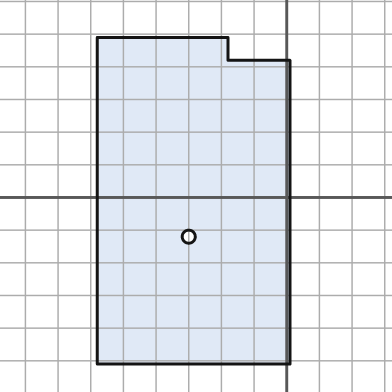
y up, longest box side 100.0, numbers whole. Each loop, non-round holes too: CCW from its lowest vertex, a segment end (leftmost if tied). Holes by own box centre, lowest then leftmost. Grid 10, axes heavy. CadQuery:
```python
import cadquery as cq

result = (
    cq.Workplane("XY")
    .moveTo(-58.0, -51.0)
    .lineTo(1.0, -51.0)
    .lineTo(1.0, 42.0)
    .lineTo(-18.0, 42.0)
    .lineTo(-18.0, 49.0)
    .lineTo(-58.0, 49.0)
    .close()
    .moveTo(-30.0, -12.0)
    .circle(2.0)
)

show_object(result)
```